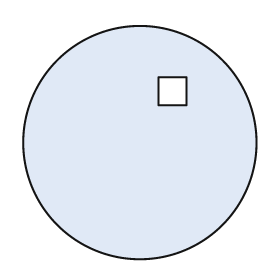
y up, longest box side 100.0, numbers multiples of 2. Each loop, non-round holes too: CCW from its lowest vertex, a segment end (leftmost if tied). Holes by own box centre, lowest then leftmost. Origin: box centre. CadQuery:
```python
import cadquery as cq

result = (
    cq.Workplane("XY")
    .moveTo(0.0, 0.0)
    .circle(50.0)
    .moveTo(8.0, 16.0)
    .lineTo(20.0, 16.0)
    .lineTo(20.0, 28.0)
    .lineTo(8.0, 28.0)
    .close()
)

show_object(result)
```